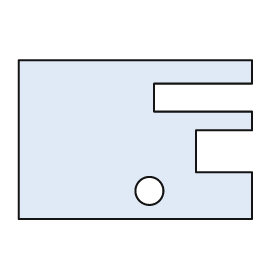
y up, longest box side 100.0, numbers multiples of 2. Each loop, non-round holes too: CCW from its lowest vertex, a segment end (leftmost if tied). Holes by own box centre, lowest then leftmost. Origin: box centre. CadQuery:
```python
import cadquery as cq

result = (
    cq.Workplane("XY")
    .moveTo(-50.0, -34.0)
    .lineTo(50.0, -34.0)
    .lineTo(50.0, -14.0)
    .lineTo(26.0, -14.0)
    .lineTo(26.0, 4.0)
    .lineTo(50.0, 4.0)
    .lineTo(50.0, 12.0)
    .lineTo(8.0, 12.0)
    .lineTo(8.0, 24.0)
    .lineTo(50.0, 24.0)
    .lineTo(50.0, 34.0)
    .lineTo(-50.0, 34.0)
    .close()
    .moveTo(6.0, -22.0)
    .circle(6.0)
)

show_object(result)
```